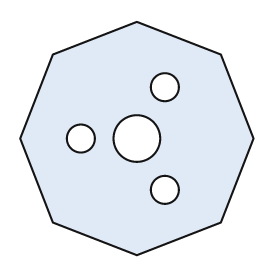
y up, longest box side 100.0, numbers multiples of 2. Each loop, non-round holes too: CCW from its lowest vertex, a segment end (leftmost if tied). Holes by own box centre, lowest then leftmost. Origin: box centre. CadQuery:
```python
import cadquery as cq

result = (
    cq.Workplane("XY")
    .moveTo(0.0, -50.0)
    .lineTo(36.0, -36.0)
    .lineTo(50.0, 0.0)
    .lineTo(36.0, 36.0)
    .lineTo(0.0, 50.0)
    .lineTo(-36.0, 36.0)
    .lineTo(-50.0, 0.0)
    .lineTo(-36.0, -36.0)
    .close()
    .moveTo(12.0, -22.0)
    .circle(6.0)
    .moveTo(-24.0, 0.0)
    .circle(6.0)
    .moveTo(0.0, 0.0)
    .circle(10.0)
    .moveTo(12.0, 22.0)
    .circle(6.0)
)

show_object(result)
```